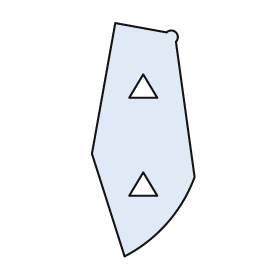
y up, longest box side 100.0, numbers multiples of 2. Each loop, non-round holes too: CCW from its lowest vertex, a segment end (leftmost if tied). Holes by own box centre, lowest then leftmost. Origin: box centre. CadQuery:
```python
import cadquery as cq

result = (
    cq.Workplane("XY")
    .moveTo(-8.0, -50.0)
    .threePointArc((10.0, -36.0), (22.0, -16.0))
    .lineTo(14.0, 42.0)
    .threePointArc((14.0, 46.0), (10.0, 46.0))
    .lineTo(-12.0, 50.0)
    .lineTo(-22.0, -6.0)
    .close()
    .moveTo(-6.0, -24.0)
    .lineTo(6.0, -24.0)
    .lineTo(0.0, -14.0)
    .close()
    .moveTo(-6.0, 18.0)
    .lineTo(6.0, 18.0)
    .lineTo(0.0, 28.0)
    .close()
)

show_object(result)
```